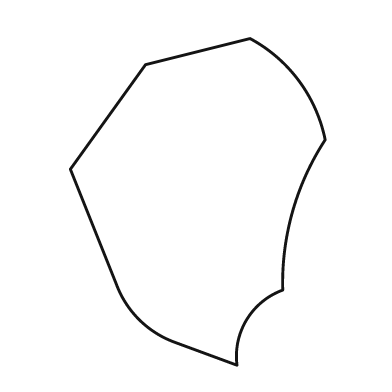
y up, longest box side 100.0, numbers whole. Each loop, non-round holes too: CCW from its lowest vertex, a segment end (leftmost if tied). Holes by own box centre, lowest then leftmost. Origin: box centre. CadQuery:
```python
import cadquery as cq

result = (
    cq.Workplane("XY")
    .moveTo(12.0, -50.0)
    .threePointArc((15.0, -36.0), (26.0, -27.0))
    .threePointArc((29.0, -3.0), (39.0, 19.0))
    .threePointArc((31.0, 37.0), (16.0, 50.0))
    .lineTo(-16.0, 42.0)
    .lineTo(-39.0, 10.0)
    .lineTo(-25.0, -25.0)
    .threePointArc((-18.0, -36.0), (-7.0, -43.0))
    .close()
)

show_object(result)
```